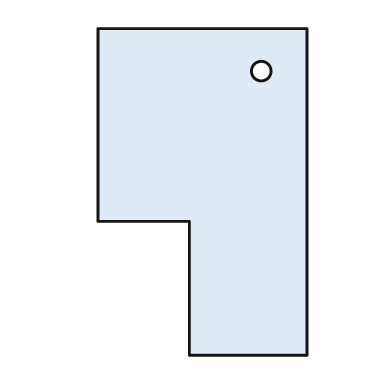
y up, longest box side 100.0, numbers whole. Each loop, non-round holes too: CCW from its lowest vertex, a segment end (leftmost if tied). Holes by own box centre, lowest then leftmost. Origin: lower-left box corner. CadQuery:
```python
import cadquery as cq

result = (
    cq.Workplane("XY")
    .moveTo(28.0, 0.0)
    .lineTo(64.0, 0.0)
    .lineTo(64.0, 100.0)
    .lineTo(0.0, 100.0)
    .lineTo(0.0, 41.0)
    .lineTo(28.0, 41.0)
    .close()
    .moveTo(50.0, 87.0)
    .circle(3.0)
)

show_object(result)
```